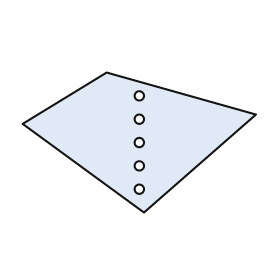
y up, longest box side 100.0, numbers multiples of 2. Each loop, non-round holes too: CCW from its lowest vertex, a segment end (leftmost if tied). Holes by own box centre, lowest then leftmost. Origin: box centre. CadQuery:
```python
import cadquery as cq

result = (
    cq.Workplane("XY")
    .moveTo(2.0, -30.0)
    .lineTo(50.0, 12.0)
    .lineTo(-14.0, 30.0)
    .lineTo(-50.0, 8.0)
    .close()
    .moveTo(0.0, -20.0)
    .circle(2.0)
    .moveTo(0.0, -10.0)
    .circle(2.0)
    .moveTo(0.0, 0.0)
    .circle(2.0)
    .moveTo(0.0, 10.0)
    .circle(2.0)
    .moveTo(0.0, 20.0)
    .circle(2.0)
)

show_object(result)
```